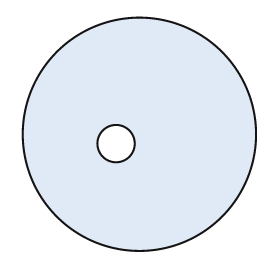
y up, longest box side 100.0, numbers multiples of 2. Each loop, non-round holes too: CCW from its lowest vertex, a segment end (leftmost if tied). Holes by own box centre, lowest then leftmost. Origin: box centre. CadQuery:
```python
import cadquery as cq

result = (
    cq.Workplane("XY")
    .moveTo(0.0, 0.0)
    .circle(50.0)
    .moveTo(-10.0, -4.0)
    .circle(8.0)
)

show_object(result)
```